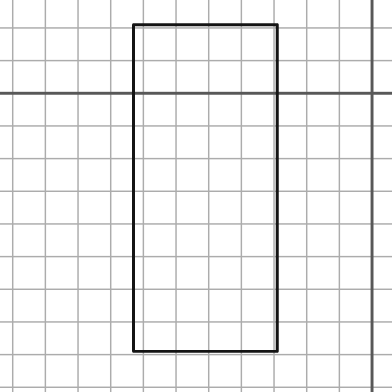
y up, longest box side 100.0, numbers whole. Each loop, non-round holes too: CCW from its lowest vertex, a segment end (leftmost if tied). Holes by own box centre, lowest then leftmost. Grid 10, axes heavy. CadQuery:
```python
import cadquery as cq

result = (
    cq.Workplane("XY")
    .moveTo(-73.0, -79.0)
    .lineTo(-29.0, -79.0)
    .lineTo(-29.0, 21.0)
    .lineTo(-73.0, 21.0)
    .close()
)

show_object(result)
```